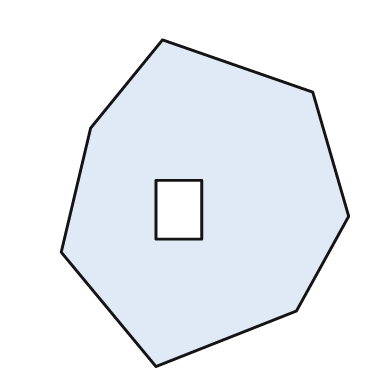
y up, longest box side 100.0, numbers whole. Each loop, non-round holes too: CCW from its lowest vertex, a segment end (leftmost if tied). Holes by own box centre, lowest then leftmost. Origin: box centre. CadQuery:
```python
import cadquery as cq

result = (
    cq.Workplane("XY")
    .moveTo(-15.0, -50.0)
    .lineTo(28.0, -33.0)
    .lineTo(44.0, -4.0)
    .lineTo(33.0, 34.0)
    .lineTo(-13.0, 50.0)
    .lineTo(-35.0, 23.0)
    .lineTo(-44.0, -15.0)
    .close()
    .moveTo(-15.0, -11.0)
    .lineTo(-1.0, -11.0)
    .lineTo(-1.0, 7.0)
    .lineTo(-15.0, 7.0)
    .close()
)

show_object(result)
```